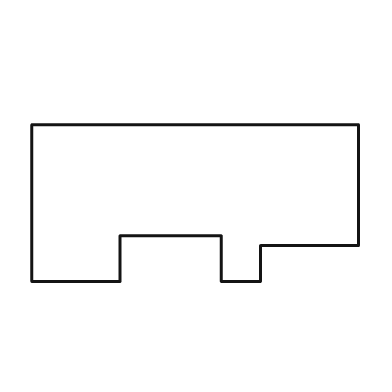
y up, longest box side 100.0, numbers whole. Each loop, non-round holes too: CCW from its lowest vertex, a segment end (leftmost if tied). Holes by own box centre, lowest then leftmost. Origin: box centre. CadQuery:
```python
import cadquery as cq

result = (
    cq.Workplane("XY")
    .moveTo(-50.0, -24.0)
    .lineTo(-23.0, -24.0)
    .lineTo(-23.0, -10.0)
    .lineTo(8.0, -10.0)
    .lineTo(8.0, -24.0)
    .lineTo(20.0, -24.0)
    .lineTo(20.0, -13.0)
    .lineTo(50.0, -13.0)
    .lineTo(50.0, 24.0)
    .lineTo(-50.0, 24.0)
    .close()
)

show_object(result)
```